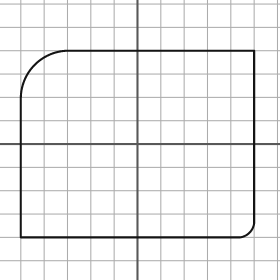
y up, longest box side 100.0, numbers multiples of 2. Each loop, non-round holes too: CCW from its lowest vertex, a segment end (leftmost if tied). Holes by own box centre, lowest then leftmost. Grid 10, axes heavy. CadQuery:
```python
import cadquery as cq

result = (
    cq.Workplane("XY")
    .moveTo(-50.0, -40.0)
    .lineTo(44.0, -40.0)
    .threePointArc((48.0, -38.0), (50.0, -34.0))
    .lineTo(50.0, 40.0)
    .lineTo(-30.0, 40.0)
    .threePointArc((-44.0, 34.0), (-50.0, 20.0))
    .close()
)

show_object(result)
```